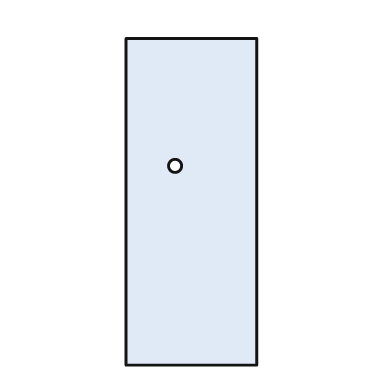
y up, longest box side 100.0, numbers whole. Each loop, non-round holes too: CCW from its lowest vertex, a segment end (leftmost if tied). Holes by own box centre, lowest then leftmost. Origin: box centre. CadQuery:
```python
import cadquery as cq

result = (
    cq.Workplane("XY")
    .moveTo(-20.0, -50.0)
    .lineTo(20.0, -50.0)
    .lineTo(20.0, 50.0)
    .lineTo(-20.0, 50.0)
    .close()
    .moveTo(-5.0, 11.0)
    .circle(2.0)
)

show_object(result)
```